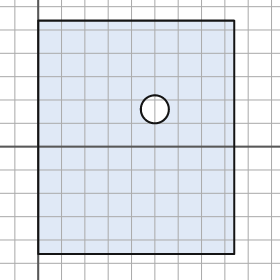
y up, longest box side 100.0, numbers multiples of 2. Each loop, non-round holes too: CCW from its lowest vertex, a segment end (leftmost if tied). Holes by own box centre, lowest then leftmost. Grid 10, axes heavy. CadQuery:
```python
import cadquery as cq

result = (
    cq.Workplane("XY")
    .moveTo(0.0, -46.0)
    .lineTo(84.0, -46.0)
    .lineTo(84.0, 54.0)
    .lineTo(0.0, 54.0)
    .close()
    .moveTo(50.0, 16.0)
    .circle(6.0)
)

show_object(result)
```